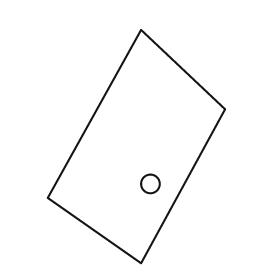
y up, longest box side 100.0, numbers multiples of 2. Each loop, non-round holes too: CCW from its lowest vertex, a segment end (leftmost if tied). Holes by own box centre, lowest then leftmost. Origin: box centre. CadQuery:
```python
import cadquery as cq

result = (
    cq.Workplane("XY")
    .moveTo(2.0, -50.0)
    .lineTo(38.0, 16.0)
    .lineTo(2.0, 50.0)
    .lineTo(-38.0, -22.0)
    .close()
    .moveTo(6.0, -16.0)
    .circle(4.0)
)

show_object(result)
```